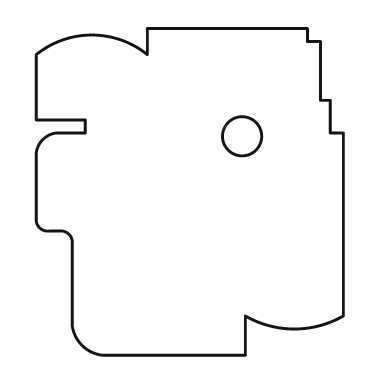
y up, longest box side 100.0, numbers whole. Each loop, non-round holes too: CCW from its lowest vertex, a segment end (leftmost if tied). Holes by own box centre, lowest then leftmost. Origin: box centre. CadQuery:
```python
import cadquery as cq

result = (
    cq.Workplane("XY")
    .moveTo(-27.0, -50.0)
    .lineTo(17.0, -50.0)
    .lineTo(17.0, -38.0)
    .threePointArc((32.0, -42.0), (47.0, -38.0))
    .lineTo(47.0, 18.0)
    .lineTo(43.0, 18.0)
    .lineTo(43.0, 28.0)
    .lineTo(40.0, 28.0)
    .lineTo(40.0, 46.0)
    .lineTo(36.0, 46.0)
    .lineTo(36.0, 50.0)
    .lineTo(-13.0, 50.0)
    .lineTo(-13.0, 42.0)
    .threePointArc((-30.0, 48.0), (-47.0, 42.0))
    .lineTo(-47.0, 22.0)
    .lineTo(-32.0, 22.0)
    .lineTo(-32.0, 18.0)
    .lineTo(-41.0, 18.0)
    .threePointArc((-45.0, 16.0), (-47.0, 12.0))
    .lineTo(-47.0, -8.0)
    .threePointArc((-46.0, -11.0), (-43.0, -12.0))
    .lineTo(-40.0, -12.0)
    .threePointArc((-37.0, -13.0), (-36.0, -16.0))
    .lineTo(-36.0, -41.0)
    .threePointArc((-33.0, -47.0), (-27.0, -50.0))
    .close()
    .moveTo(16.0, 17.0)
    .circle(6.0)
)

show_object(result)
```